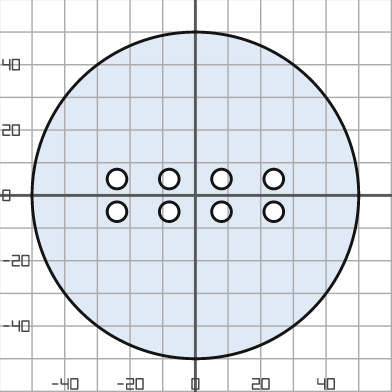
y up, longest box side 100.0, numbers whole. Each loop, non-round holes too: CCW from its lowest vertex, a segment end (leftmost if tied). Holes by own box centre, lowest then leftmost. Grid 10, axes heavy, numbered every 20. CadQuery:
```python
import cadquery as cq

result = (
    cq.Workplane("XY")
    .moveTo(0.0, 0.0)
    .circle(50.0)
    .moveTo(-24.0, -5.0)
    .circle(3.0)
    .moveTo(-8.0, -5.0)
    .circle(3.0)
    .moveTo(8.0, -5.0)
    .circle(3.0)
    .moveTo(24.0, -5.0)
    .circle(3.0)
    .moveTo(-24.0, 5.0)
    .circle(3.0)
    .moveTo(-8.0, 5.0)
    .circle(3.0)
    .moveTo(8.0, 5.0)
    .circle(3.0)
    .moveTo(24.0, 5.0)
    .circle(3.0)
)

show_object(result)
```